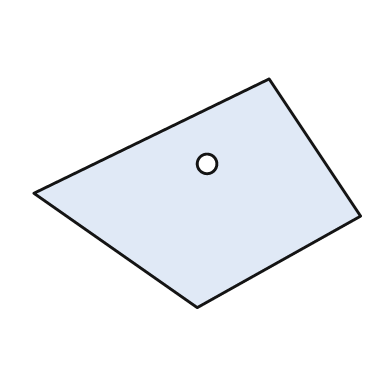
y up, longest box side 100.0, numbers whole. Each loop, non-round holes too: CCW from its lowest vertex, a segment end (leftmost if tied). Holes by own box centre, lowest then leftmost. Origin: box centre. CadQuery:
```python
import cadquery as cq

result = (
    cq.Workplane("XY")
    .moveTo(0.0, -35.0)
    .lineTo(50.0, -7.0)
    .lineTo(22.0, 35.0)
    .lineTo(-50.0, 0.0)
    .close()
    .moveTo(3.0, 9.0)
    .circle(3.0)
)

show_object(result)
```